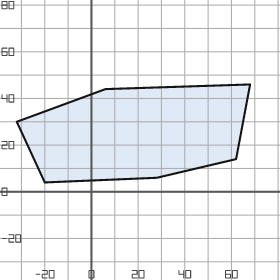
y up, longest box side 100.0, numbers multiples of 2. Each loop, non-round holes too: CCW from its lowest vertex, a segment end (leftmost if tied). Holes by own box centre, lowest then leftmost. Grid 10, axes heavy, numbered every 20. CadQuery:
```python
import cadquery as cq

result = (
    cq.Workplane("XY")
    .moveTo(-20.0, 4.0)
    .lineTo(28.0, 6.0)
    .lineTo(62.0, 14.0)
    .lineTo(68.0, 46.0)
    .lineTo(6.0, 44.0)
    .lineTo(-32.0, 30.0)
    .close()
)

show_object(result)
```